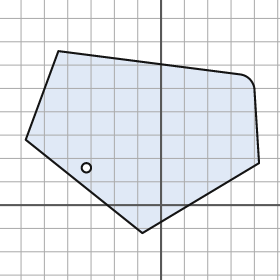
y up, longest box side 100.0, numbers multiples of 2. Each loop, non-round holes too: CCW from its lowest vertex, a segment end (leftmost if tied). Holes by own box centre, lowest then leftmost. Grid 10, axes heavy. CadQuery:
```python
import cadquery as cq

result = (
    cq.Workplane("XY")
    .moveTo(-8.0, -12.0)
    .lineTo(42.0, 18.0)
    .lineTo(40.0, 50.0)
    .threePointArc((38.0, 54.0), (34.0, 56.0))
    .lineTo(-44.0, 66.0)
    .lineTo(-58.0, 28.0)
    .close()
    .moveTo(-32.0, 16.0)
    .circle(2.0)
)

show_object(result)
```